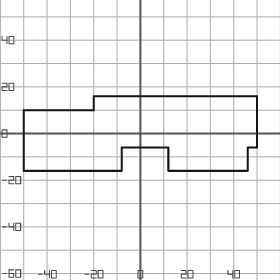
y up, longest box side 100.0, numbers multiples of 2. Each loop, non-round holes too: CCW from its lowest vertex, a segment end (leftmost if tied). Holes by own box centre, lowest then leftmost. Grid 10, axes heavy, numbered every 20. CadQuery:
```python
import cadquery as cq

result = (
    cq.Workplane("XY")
    .moveTo(-50.0, -16.0)
    .lineTo(-8.0, -16.0)
    .lineTo(-8.0, -6.0)
    .lineTo(12.0, -6.0)
    .lineTo(12.0, -16.0)
    .lineTo(46.0, -16.0)
    .lineTo(46.0, -6.0)
    .lineTo(50.0, -6.0)
    .lineTo(50.0, 16.0)
    .lineTo(-20.0, 16.0)
    .lineTo(-20.0, 10.0)
    .lineTo(-50.0, 10.0)
    .close()
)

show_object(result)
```